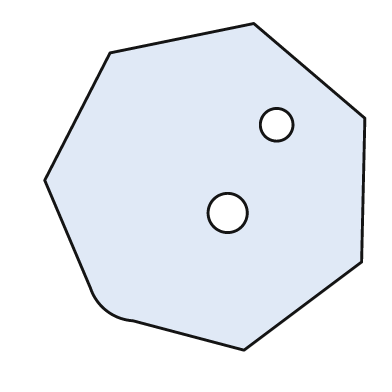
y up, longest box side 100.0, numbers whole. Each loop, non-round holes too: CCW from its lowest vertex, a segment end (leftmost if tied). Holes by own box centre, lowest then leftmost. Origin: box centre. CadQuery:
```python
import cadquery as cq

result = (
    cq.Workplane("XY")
    .moveTo(12.0, -50.0)
    .lineTo(48.0, -23.0)
    .lineTo(49.0, 21.0)
    .lineTo(15.0, 50.0)
    .lineTo(-29.0, 41.0)
    .lineTo(-49.0, 2.0)
    .lineTo(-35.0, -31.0)
    .threePointArc((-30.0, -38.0), (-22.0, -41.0))
    .close()
    .moveTo(7.0, -8.0)
    .circle(6.0)
    .moveTo(22.0, 19.0)
    .circle(5.0)
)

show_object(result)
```